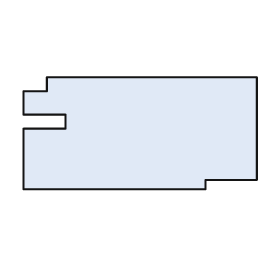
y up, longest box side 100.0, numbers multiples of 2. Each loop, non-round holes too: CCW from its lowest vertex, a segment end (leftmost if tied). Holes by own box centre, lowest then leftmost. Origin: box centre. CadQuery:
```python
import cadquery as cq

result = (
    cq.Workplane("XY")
    .moveTo(-50.0, -24.0)
    .lineTo(28.0, -24.0)
    .lineTo(28.0, -20.0)
    .lineTo(50.0, -20.0)
    .lineTo(50.0, 24.0)
    .lineTo(-40.0, 24.0)
    .lineTo(-40.0, 18.0)
    .lineTo(-50.0, 18.0)
    .lineTo(-50.0, 8.0)
    .lineTo(-32.0, 8.0)
    .lineTo(-32.0, 2.0)
    .lineTo(-50.0, 2.0)
    .close()
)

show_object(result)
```